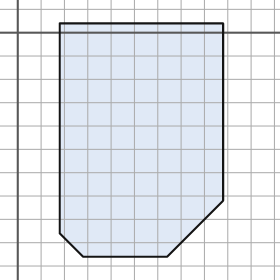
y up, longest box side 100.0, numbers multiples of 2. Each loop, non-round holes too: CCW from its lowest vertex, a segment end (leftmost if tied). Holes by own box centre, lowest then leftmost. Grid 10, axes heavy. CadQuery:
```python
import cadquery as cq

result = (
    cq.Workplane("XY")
    .moveTo(28.0, -96.0)
    .lineTo(64.0, -96.0)
    .lineTo(88.0, -72.0)
    .lineTo(88.0, 4.0)
    .lineTo(18.0, 4.0)
    .lineTo(18.0, -86.0)
    .close()
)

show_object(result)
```